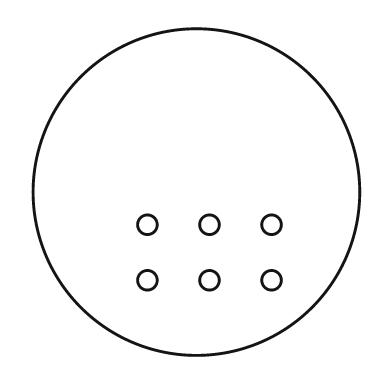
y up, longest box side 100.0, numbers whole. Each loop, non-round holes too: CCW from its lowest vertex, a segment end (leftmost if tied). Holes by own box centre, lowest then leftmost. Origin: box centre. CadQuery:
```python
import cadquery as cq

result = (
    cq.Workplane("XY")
    .moveTo(0.0, 0.0)
    .circle(50.0)
    .moveTo(-15.0, -27.0)
    .circle(3.0)
    .moveTo(4.0, -27.0)
    .circle(3.0)
    .moveTo(23.0, -27.0)
    .circle(3.0)
    .moveTo(-15.0, -10.0)
    .circle(3.0)
    .moveTo(4.0, -10.0)
    .circle(3.0)
    .moveTo(23.0, -10.0)
    .circle(3.0)
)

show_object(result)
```